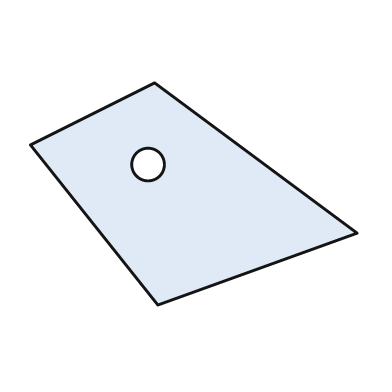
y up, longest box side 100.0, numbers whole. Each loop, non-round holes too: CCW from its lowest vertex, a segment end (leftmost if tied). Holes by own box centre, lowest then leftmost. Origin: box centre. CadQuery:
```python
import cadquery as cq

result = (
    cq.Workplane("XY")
    .moveTo(-11.0, -34.0)
    .lineTo(50.0, -12.0)
    .lineTo(-12.0, 34.0)
    .lineTo(-50.0, 15.0)
    .close()
    .moveTo(-14.0, 9.0)
    .circle(5.0)
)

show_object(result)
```